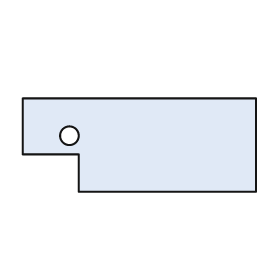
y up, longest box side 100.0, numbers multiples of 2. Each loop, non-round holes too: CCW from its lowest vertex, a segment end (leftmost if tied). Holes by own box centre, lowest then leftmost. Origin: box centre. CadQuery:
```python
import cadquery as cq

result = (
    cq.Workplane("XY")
    .moveTo(-26.0, -20.0)
    .lineTo(50.0, -20.0)
    .lineTo(50.0, 20.0)
    .lineTo(-50.0, 20.0)
    .lineTo(-50.0, -4.0)
    .lineTo(-26.0, -4.0)
    .close()
    .moveTo(-30.0, 4.0)
    .circle(4.0)
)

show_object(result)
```